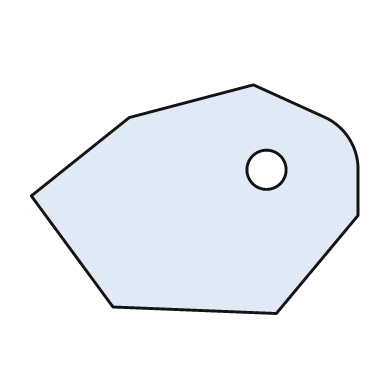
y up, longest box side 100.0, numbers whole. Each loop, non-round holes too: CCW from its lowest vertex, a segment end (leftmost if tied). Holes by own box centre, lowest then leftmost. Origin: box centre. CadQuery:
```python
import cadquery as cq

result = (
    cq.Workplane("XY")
    .moveTo(25.0, -35.0)
    .lineTo(50.0, -5.0)
    .lineTo(50.0, 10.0)
    .threePointArc((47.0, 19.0), (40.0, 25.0))
    .lineTo(18.0, 35.0)
    .lineTo(-20.0, 25.0)
    .lineTo(-50.0, 1.0)
    .lineTo(-25.0, -33.0)
    .close()
    .moveTo(22.0, 9.0)
    .circle(6.0)
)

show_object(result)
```